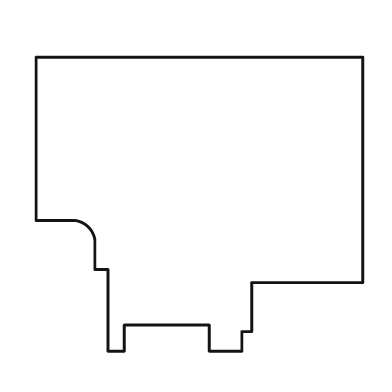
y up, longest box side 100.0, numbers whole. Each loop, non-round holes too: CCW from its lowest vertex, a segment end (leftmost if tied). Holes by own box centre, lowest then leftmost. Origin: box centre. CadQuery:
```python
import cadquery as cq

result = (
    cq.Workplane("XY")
    .moveTo(-28.0, -45.0)
    .lineTo(-23.0, -45.0)
    .lineTo(-23.0, -37.0)
    .lineTo(3.0, -37.0)
    .lineTo(3.0, -45.0)
    .lineTo(13.0, -45.0)
    .lineTo(13.0, -39.0)
    .lineTo(16.0, -39.0)
    .lineTo(16.0, -24.0)
    .lineTo(50.0, -24.0)
    .lineTo(50.0, 45.0)
    .lineTo(-50.0, 45.0)
    .lineTo(-50.0, -5.0)
    .lineTo(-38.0, -5.0)
    .threePointArc((-34.0, -7.0), (-32.0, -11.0))
    .lineTo(-32.0, -20.0)
    .lineTo(-28.0, -20.0)
    .close()
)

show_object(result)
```